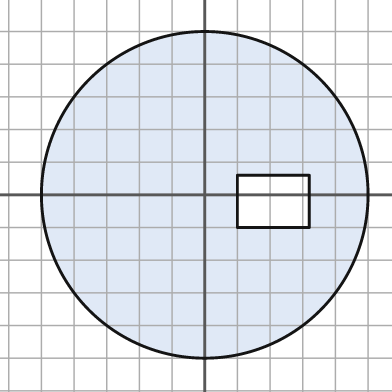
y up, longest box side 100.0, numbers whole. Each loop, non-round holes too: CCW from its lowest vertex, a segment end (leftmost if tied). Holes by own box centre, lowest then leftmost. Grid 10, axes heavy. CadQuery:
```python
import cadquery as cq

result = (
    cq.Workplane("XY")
    .moveTo(0.0, 0.0)
    .circle(50.0)
    .moveTo(10.0, -10.0)
    .lineTo(32.0, -10.0)
    .lineTo(32.0, 6.0)
    .lineTo(10.0, 6.0)
    .close()
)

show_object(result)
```